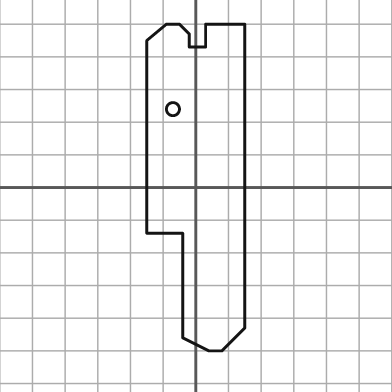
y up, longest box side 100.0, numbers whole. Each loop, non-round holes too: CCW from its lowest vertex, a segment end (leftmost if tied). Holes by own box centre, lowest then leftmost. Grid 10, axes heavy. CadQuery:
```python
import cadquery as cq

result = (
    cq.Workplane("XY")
    .moveTo(4.0, -50.0)
    .lineTo(8.0, -50.0)
    .lineTo(15.0, -43.0)
    .lineTo(15.0, 50.0)
    .lineTo(3.0, 50.0)
    .lineTo(3.0, 43.0)
    .lineTo(-2.0, 43.0)
    .lineTo(-2.0, 47.0)
    .lineTo(-5.0, 50.0)
    .lineTo(-9.0, 50.0)
    .lineTo(-15.0, 45.0)
    .lineTo(-15.0, -14.0)
    .lineTo(-4.0, -14.0)
    .lineTo(-4.0, -46.0)
    .close()
    .moveTo(-7.0, 24.0)
    .circle(2.0)
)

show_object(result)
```